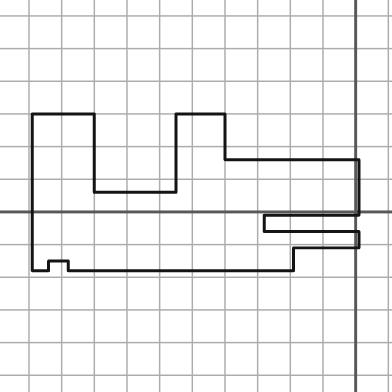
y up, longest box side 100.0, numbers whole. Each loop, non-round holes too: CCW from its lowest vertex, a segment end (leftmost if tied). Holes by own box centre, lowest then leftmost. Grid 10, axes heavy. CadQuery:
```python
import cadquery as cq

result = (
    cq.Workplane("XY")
    .moveTo(-99.0, -18.0)
    .lineTo(-94.0, -18.0)
    .lineTo(-94.0, -15.0)
    .lineTo(-88.0, -15.0)
    .lineTo(-88.0, -18.0)
    .lineTo(-19.0, -18.0)
    .lineTo(-19.0, -11.0)
    .lineTo(1.0, -11.0)
    .lineTo(1.0, -6.0)
    .lineTo(-28.0, -6.0)
    .lineTo(-28.0, -1.0)
    .lineTo(1.0, -1.0)
    .lineTo(1.0, 16.0)
    .lineTo(-40.0, 16.0)
    .lineTo(-40.0, 30.0)
    .lineTo(-55.0, 30.0)
    .lineTo(-55.0, 6.0)
    .lineTo(-80.0, 6.0)
    .lineTo(-80.0, 30.0)
    .lineTo(-99.0, 30.0)
    .close()
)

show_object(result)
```